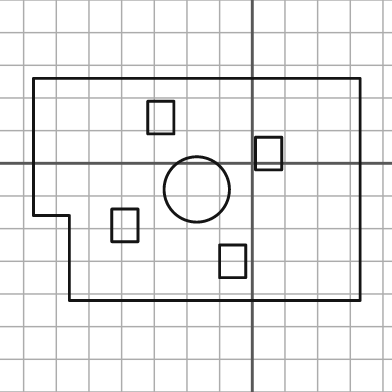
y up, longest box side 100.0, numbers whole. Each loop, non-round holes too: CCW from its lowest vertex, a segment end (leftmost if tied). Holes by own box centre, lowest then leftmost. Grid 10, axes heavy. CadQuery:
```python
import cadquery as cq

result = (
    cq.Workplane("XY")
    .moveTo(-56.0, -42.0)
    .lineTo(33.0, -42.0)
    .lineTo(33.0, 26.0)
    .lineTo(-67.0, 26.0)
    .lineTo(-67.0, -16.0)
    .lineTo(-56.0, -16.0)
    .close()
    .moveTo(-10.0, -35.0)
    .lineTo(-2.0, -35.0)
    .lineTo(-2.0, -25.0)
    .lineTo(-10.0, -25.0)
    .close()
    .moveTo(-43.0, -24.0)
    .lineTo(-35.0, -24.0)
    .lineTo(-35.0, -14.0)
    .lineTo(-43.0, -14.0)
    .close()
    .moveTo(-17.0, -8.0)
    .circle(10.0)
    .moveTo(1.0, -2.0)
    .lineTo(9.0, -2.0)
    .lineTo(9.0, 8.0)
    .lineTo(1.0, 8.0)
    .close()
    .moveTo(-32.0, 9.0)
    .lineTo(-24.0, 9.0)
    .lineTo(-24.0, 19.0)
    .lineTo(-32.0, 19.0)
    .close()
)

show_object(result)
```